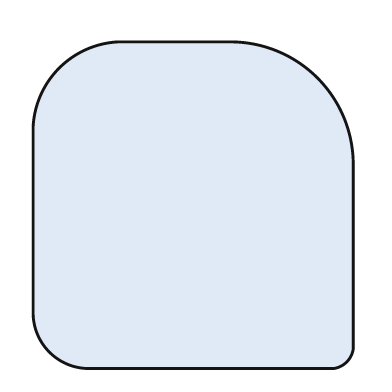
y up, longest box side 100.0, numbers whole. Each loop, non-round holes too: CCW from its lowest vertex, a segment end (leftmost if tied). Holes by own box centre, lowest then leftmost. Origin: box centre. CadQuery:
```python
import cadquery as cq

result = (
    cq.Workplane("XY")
    .moveTo(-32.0, -50.0)
    .lineTo(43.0, -50.0)
    .threePointArc((47.0, -48.0), (49.0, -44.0))
    .lineTo(49.0, 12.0)
    .threePointArc((38.0, 39.0), (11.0, 50.0))
    .lineTo(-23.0, 50.0)
    .threePointArc((-41.0, 42.0), (-49.0, 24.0))
    .lineTo(-49.0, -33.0)
    .threePointArc((-44.0, -45.0), (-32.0, -50.0))
    .close()
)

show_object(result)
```